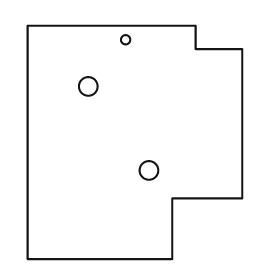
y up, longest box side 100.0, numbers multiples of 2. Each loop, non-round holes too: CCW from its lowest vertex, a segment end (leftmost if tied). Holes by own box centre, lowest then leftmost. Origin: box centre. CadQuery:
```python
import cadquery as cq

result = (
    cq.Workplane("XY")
    .moveTo(-46.0, -50.0)
    .lineTo(16.0, -50.0)
    .lineTo(16.0, -24.0)
    .lineTo(46.0, -24.0)
    .lineTo(46.0, 40.0)
    .lineTo(26.0, 40.0)
    .lineTo(26.0, 50.0)
    .lineTo(-46.0, 50.0)
    .close()
    .moveTo(6.0, -12.0)
    .circle(4.0)
    .moveTo(-20.0, 24.0)
    .circle(4.0)
    .moveTo(-4.0, 44.0)
    .circle(2.0)
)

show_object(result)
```